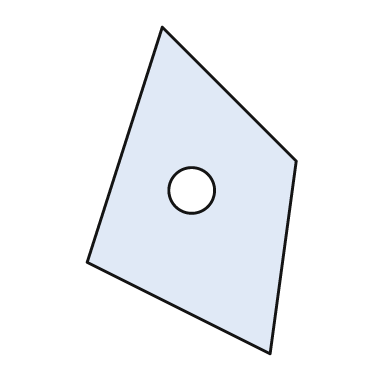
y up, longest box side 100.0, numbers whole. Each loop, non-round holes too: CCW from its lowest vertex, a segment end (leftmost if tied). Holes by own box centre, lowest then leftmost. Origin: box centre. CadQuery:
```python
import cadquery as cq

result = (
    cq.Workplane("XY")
    .moveTo(24.0, -50.0)
    .lineTo(32.0, 9.0)
    .lineTo(-9.0, 50.0)
    .lineTo(-32.0, -22.0)
    .close()
    .moveTo(0.0, 0.0)
    .circle(7.0)
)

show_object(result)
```